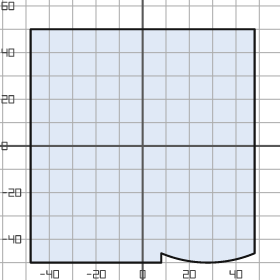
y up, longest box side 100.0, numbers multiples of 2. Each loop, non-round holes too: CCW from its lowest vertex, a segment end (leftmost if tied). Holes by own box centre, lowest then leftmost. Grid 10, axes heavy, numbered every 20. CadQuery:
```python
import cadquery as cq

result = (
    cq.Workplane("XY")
    .moveTo(-48.0, -50.0)
    .lineTo(8.0, -50.0)
    .lineTo(8.0, -46.0)
    .threePointArc((28.0, -50.0), (48.0, -46.0))
    .lineTo(48.0, 50.0)
    .lineTo(-48.0, 50.0)
    .close()
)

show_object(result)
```